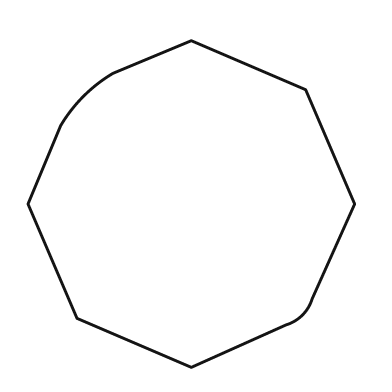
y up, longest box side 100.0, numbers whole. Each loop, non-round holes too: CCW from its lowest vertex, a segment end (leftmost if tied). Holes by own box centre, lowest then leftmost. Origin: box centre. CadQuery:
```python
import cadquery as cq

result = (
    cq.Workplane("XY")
    .moveTo(0.0, -50.0)
    .lineTo(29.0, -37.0)
    .threePointArc((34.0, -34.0), (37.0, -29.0))
    .lineTo(50.0, 0.0)
    .lineTo(35.0, 35.0)
    .lineTo(0.0, 50.0)
    .lineTo(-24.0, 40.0)
    .threePointArc((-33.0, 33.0), (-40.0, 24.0))
    .lineTo(-50.0, 0.0)
    .lineTo(-35.0, -35.0)
    .close()
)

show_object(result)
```